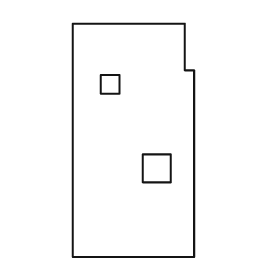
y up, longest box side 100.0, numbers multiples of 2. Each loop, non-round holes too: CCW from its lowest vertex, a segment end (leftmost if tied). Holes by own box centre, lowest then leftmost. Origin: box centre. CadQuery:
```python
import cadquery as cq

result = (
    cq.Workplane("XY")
    .moveTo(-26.0, -50.0)
    .lineTo(26.0, -50.0)
    .lineTo(26.0, 30.0)
    .lineTo(22.0, 30.0)
    .lineTo(22.0, 50.0)
    .lineTo(-26.0, 50.0)
    .close()
    .moveTo(4.0, -18.0)
    .lineTo(16.0, -18.0)
    .lineTo(16.0, -6.0)
    .lineTo(4.0, -6.0)
    .close()
    .moveTo(-14.0, 20.0)
    .lineTo(-6.0, 20.0)
    .lineTo(-6.0, 28.0)
    .lineTo(-14.0, 28.0)
    .close()
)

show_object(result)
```